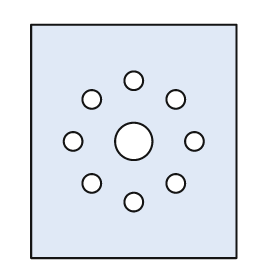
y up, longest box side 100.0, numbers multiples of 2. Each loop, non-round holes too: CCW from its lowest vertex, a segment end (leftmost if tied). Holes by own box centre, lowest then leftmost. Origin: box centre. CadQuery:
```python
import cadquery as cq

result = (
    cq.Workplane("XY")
    .moveTo(-44.0, -50.0)
    .lineTo(44.0, -50.0)
    .lineTo(44.0, 50.0)
    .lineTo(-44.0, 50.0)
    .close()
    .moveTo(0.0, -26.0)
    .circle(4.0)
    .moveTo(-18.0, -18.0)
    .circle(4.0)
    .moveTo(18.0, -18.0)
    .circle(4.0)
    .moveTo(-26.0, 0.0)
    .circle(4.0)
    .moveTo(0.0, 0.0)
    .circle(8.0)
    .moveTo(26.0, 0.0)
    .circle(4.0)
    .moveTo(-18.0, 18.0)
    .circle(4.0)
    .moveTo(18.0, 18.0)
    .circle(4.0)
    .moveTo(0.0, 26.0)
    .circle(4.0)
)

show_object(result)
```